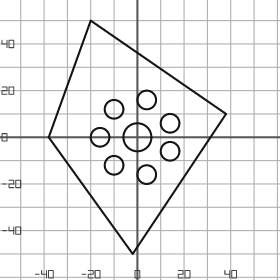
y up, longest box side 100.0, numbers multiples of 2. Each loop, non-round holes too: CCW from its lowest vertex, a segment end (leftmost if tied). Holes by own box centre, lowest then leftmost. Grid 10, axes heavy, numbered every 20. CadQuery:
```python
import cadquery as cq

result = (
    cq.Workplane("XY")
    .moveTo(-2.0, -50.0)
    .lineTo(38.0, 10.0)
    .lineTo(-20.0, 50.0)
    .lineTo(-38.0, 0.0)
    .close()
    .moveTo(4.0, -16.0)
    .circle(4.0)
    .moveTo(-10.0, -12.0)
    .circle(4.0)
    .moveTo(14.0, -6.0)
    .circle(4.0)
    .moveTo(-16.0, 0.0)
    .circle(4.0)
    .moveTo(0.0, 0.0)
    .circle(6.0)
    .moveTo(14.0, 6.0)
    .circle(4.0)
    .moveTo(-10.0, 12.0)
    .circle(4.0)
    .moveTo(4.0, 16.0)
    .circle(4.0)
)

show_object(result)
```